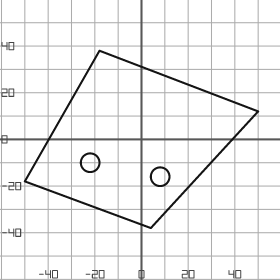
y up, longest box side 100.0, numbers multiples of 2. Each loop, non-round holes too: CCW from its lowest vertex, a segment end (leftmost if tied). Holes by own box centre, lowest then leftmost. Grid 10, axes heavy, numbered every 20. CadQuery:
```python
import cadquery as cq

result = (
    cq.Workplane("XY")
    .moveTo(4.0, -38.0)
    .lineTo(50.0, 12.0)
    .lineTo(-18.0, 38.0)
    .lineTo(-50.0, -18.0)
    .close()
    .moveTo(8.0, -16.0)
    .circle(4.0)
    .moveTo(-22.0, -10.0)
    .circle(4.0)
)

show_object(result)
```